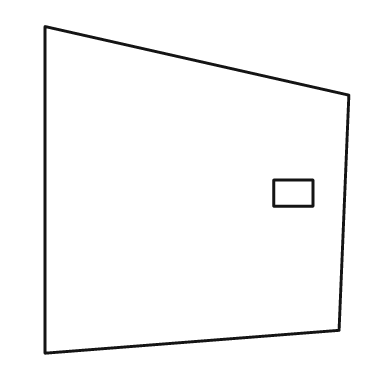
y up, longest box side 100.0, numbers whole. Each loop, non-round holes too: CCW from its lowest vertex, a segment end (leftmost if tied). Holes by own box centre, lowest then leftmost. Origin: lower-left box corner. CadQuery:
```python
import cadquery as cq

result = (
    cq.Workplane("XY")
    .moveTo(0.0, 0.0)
    .lineTo(90.0, 7.0)
    .lineTo(93.0, 79.0)
    .lineTo(0.0, 100.0)
    .close()
    .moveTo(70.0, 45.0)
    .lineTo(82.0, 45.0)
    .lineTo(82.0, 53.0)
    .lineTo(70.0, 53.0)
    .close()
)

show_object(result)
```